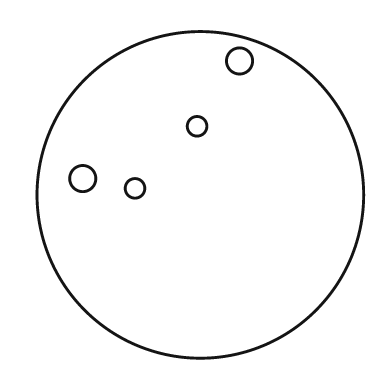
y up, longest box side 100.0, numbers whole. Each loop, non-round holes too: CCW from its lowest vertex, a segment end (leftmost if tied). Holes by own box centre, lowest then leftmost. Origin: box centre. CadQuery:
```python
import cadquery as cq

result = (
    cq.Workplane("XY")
    .moveTo(0.0, 0.0)
    .circle(50.0)
    .moveTo(-20.0, 2.0)
    .circle(3.0)
    .moveTo(-36.0, 5.0)
    .circle(4.0)
    .moveTo(-1.0, 21.0)
    .circle(3.0)
    .moveTo(12.0, 41.0)
    .circle(4.0)
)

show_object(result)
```